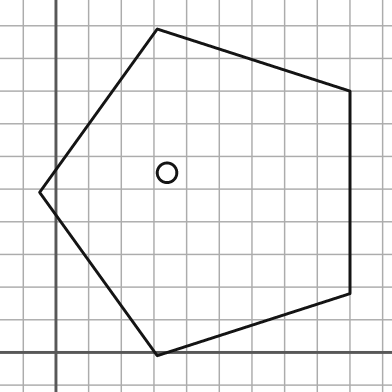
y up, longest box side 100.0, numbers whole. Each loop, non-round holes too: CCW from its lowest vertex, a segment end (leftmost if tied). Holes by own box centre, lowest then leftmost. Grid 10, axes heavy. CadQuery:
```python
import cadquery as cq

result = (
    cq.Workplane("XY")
    .moveTo(31.0, -1.0)
    .lineTo(90.0, 18.0)
    .lineTo(90.0, 80.0)
    .lineTo(31.0, 99.0)
    .lineTo(-5.0, 49.0)
    .close()
    .moveTo(34.0, 55.0)
    .circle(3.0)
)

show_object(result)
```